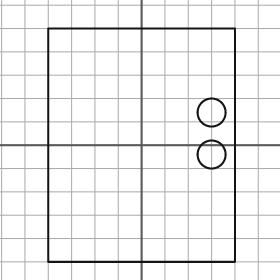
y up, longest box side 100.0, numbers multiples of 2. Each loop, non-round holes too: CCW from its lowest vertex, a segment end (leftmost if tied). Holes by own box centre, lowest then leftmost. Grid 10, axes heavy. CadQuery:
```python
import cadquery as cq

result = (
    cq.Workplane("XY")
    .moveTo(-40.0, -50.0)
    .lineTo(40.0, -50.0)
    .lineTo(40.0, 50.0)
    .lineTo(-40.0, 50.0)
    .close()
    .moveTo(30.0, -4.0)
    .circle(6.0)
    .moveTo(30.0, 14.0)
    .circle(6.0)
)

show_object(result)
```